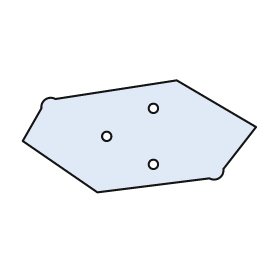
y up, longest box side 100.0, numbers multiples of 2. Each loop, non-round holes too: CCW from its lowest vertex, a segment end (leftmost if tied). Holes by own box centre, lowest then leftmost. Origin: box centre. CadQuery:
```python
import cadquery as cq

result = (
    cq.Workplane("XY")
    .moveTo(-18.0, -24.0)
    .lineTo(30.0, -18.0)
    .threePointArc((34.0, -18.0), (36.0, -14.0))
    .lineTo(50.0, 4.0)
    .lineTo(16.0, 24.0)
    .lineTo(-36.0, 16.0)
    .threePointArc((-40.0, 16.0), (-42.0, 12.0))
    .lineTo(-50.0, -2.0)
    .close()
    .moveTo(6.0, -12.0)
    .circle(2.0)
    .moveTo(-14.0, 0.0)
    .circle(2.0)
    .moveTo(6.0, 12.0)
    .circle(2.0)
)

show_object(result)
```